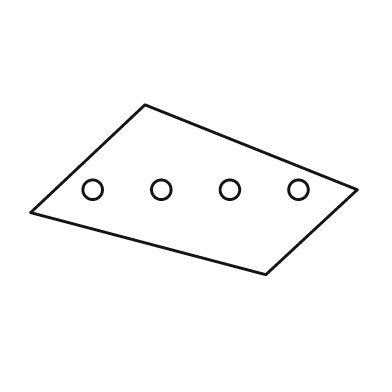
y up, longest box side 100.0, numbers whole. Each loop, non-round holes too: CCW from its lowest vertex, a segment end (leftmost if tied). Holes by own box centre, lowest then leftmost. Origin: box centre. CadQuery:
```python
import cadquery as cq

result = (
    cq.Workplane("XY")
    .moveTo(22.0, -26.0)
    .lineTo(50.0, 0.0)
    .lineTo(-15.0, 26.0)
    .lineTo(-50.0, -7.0)
    .close()
    .moveTo(-31.0, 0.0)
    .circle(3.0)
    .moveTo(-10.0, 0.0)
    .circle(3.0)
    .moveTo(11.0, 0.0)
    .circle(3.0)
    .moveTo(32.0, 0.0)
    .circle(3.0)
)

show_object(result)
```